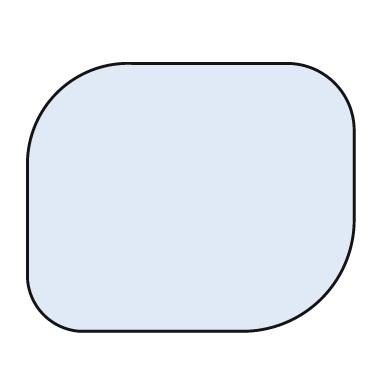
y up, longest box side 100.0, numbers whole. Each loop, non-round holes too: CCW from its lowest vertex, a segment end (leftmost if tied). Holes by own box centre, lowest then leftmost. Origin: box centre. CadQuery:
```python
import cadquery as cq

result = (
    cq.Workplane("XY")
    .moveTo(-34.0, -41.0)
    .lineTo(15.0, -41.0)
    .threePointArc((40.0, -31.0), (50.0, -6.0))
    .lineTo(50.0, 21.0)
    .threePointArc((44.0, 35.0), (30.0, 41.0))
    .lineTo(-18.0, 41.0)
    .threePointArc((-41.0, 32.0), (-50.0, 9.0))
    .lineTo(-50.0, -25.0)
    .threePointArc((-45.0, -36.0), (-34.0, -41.0))
    .close()
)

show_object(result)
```